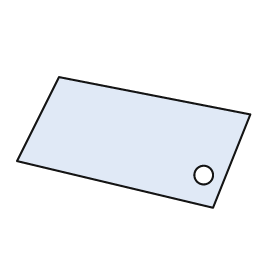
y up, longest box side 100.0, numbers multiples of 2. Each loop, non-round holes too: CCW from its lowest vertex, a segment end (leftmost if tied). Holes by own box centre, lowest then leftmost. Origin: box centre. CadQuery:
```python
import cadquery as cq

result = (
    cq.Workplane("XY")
    .moveTo(34.0, -28.0)
    .lineTo(50.0, 12.0)
    .lineTo(-32.0, 28.0)
    .lineTo(-50.0, -8.0)
    .close()
    .moveTo(30.0, -14.0)
    .circle(4.0)
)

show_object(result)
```